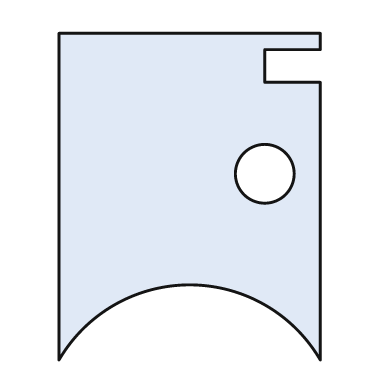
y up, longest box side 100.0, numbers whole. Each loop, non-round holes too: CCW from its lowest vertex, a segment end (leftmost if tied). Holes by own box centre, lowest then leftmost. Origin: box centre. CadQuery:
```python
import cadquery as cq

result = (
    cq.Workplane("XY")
    .moveTo(-40.0, -50.0)
    .threePointArc((0.0, -27.0), (40.0, -50.0))
    .lineTo(40.0, 35.0)
    .lineTo(23.0, 35.0)
    .lineTo(23.0, 45.0)
    .lineTo(40.0, 45.0)
    .lineTo(40.0, 50.0)
    .lineTo(-40.0, 50.0)
    .close()
    .moveTo(23.0, 7.0)
    .circle(9.0)
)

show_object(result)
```